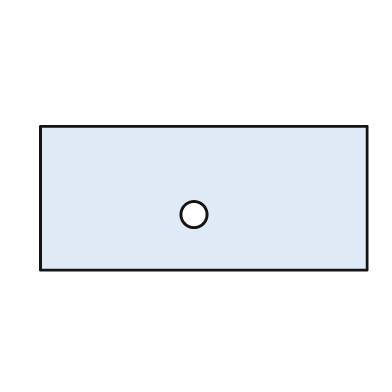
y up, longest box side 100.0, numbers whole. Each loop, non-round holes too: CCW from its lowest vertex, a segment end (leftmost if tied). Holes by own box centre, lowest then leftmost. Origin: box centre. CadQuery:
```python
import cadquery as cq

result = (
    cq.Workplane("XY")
    .moveTo(-50.0, -22.0)
    .lineTo(50.0, -22.0)
    .lineTo(50.0, 22.0)
    .lineTo(-50.0, 22.0)
    .close()
    .moveTo(-3.0, -5.0)
    .circle(4.0)
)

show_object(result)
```